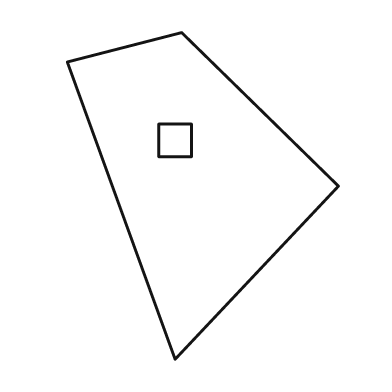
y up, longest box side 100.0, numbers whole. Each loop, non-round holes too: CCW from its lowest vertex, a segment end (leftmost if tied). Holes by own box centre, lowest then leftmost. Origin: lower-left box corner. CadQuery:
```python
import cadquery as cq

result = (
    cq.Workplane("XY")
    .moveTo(33.0, 0.0)
    .lineTo(83.0, 53.0)
    .lineTo(35.0, 100.0)
    .lineTo(0.0, 91.0)
    .close()
    .moveTo(28.0, 62.0)
    .lineTo(38.0, 62.0)
    .lineTo(38.0, 72.0)
    .lineTo(28.0, 72.0)
    .close()
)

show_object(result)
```